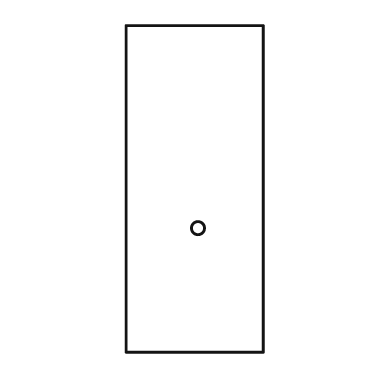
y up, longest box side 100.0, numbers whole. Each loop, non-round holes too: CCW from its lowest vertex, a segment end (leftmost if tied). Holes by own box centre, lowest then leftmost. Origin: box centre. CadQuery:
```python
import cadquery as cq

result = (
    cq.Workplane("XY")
    .moveTo(-21.0, -50.0)
    .lineTo(21.0, -50.0)
    .lineTo(21.0, 50.0)
    .lineTo(-21.0, 50.0)
    .close()
    .moveTo(1.0, -12.0)
    .circle(2.0)
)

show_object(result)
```